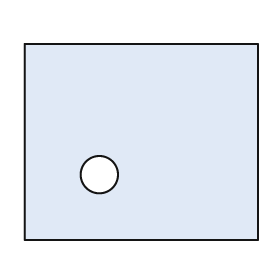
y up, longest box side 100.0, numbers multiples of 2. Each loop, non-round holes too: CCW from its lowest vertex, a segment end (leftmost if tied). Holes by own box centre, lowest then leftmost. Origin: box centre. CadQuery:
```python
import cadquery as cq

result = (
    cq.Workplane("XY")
    .moveTo(-50.0, -42.0)
    .lineTo(50.0, -42.0)
    .lineTo(50.0, 42.0)
    .lineTo(-50.0, 42.0)
    .close()
    .moveTo(-18.0, -14.0)
    .circle(8.0)
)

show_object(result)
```